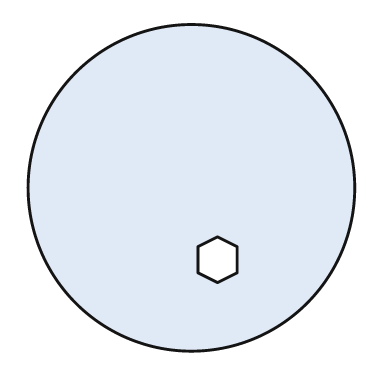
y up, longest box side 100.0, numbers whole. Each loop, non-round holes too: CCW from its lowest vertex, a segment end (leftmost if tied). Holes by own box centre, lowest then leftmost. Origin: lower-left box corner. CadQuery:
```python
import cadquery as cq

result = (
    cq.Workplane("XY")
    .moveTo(50.0, 50.0)
    .circle(50.0)
    .moveTo(58.0, 21.0)
    .lineTo(64.0, 24.0)
    .lineTo(64.0, 32.0)
    .lineTo(58.0, 35.0)
    .lineTo(52.0, 32.0)
    .lineTo(52.0, 24.0)
    .close()
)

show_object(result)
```